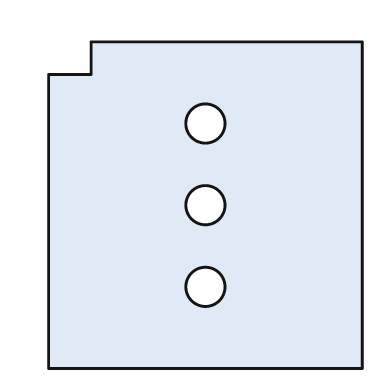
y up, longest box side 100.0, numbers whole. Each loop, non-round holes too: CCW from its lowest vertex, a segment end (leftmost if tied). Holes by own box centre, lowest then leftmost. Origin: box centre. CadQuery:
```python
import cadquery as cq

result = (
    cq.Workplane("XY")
    .moveTo(-48.0, -50.0)
    .lineTo(48.0, -50.0)
    .lineTo(48.0, 50.0)
    .lineTo(-35.0, 50.0)
    .lineTo(-35.0, 40.0)
    .lineTo(-48.0, 40.0)
    .close()
    .moveTo(0.0, -25.0)
    .circle(6.0)
    .moveTo(0.0, 0.0)
    .circle(6.0)
    .moveTo(0.0, 25.0)
    .circle(6.0)
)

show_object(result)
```